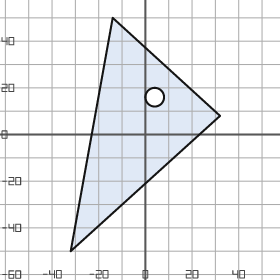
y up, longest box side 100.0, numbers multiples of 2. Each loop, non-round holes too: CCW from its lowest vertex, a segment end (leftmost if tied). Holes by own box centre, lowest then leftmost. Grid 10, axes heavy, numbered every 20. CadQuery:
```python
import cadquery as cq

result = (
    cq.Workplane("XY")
    .moveTo(-32.0, -50.0)
    .lineTo(32.0, 8.0)
    .lineTo(-14.0, 50.0)
    .close()
    .moveTo(4.0, 16.0)
    .circle(4.0)
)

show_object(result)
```